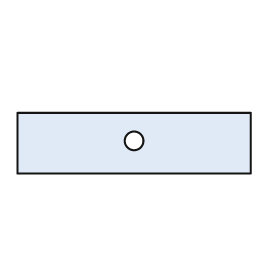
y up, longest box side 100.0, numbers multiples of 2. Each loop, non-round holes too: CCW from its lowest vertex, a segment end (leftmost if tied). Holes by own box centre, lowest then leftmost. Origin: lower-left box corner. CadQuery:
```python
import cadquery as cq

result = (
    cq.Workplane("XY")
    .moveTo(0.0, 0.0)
    .lineTo(100.0, 0.0)
    .lineTo(100.0, 26.0)
    .lineTo(0.0, 26.0)
    .close()
    .moveTo(50.0, 14.0)
    .circle(4.0)
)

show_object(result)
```